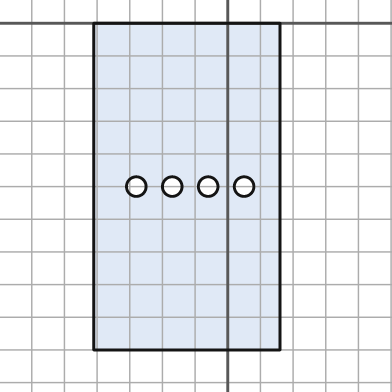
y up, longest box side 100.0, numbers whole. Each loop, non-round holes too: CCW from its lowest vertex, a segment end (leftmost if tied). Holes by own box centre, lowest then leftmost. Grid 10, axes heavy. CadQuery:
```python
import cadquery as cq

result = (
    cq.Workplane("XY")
    .moveTo(-41.0, -100.0)
    .lineTo(16.0, -100.0)
    .lineTo(16.0, 0.0)
    .lineTo(-41.0, 0.0)
    .close()
    .moveTo(-28.0, -50.0)
    .circle(3.0)
    .moveTo(-17.0, -50.0)
    .circle(3.0)
    .moveTo(-6.0, -50.0)
    .circle(3.0)
    .moveTo(5.0, -50.0)
    .circle(3.0)
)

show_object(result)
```